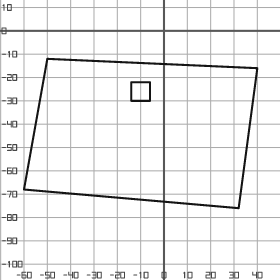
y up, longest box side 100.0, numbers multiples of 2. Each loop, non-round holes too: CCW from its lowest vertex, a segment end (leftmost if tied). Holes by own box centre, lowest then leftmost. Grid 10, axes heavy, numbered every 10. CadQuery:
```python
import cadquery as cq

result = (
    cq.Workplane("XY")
    .moveTo(32.0, -76.0)
    .lineTo(40.0, -16.0)
    .lineTo(-50.0, -12.0)
    .lineTo(-60.0, -68.0)
    .close()
    .moveTo(-14.0, -30.0)
    .lineTo(-6.0, -30.0)
    .lineTo(-6.0, -22.0)
    .lineTo(-14.0, -22.0)
    .close()
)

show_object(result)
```